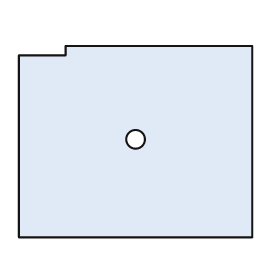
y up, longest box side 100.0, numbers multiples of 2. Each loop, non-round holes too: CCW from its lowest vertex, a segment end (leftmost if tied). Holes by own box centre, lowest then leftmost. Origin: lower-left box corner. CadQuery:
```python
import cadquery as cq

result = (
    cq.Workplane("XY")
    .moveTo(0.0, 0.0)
    .lineTo(100.0, 0.0)
    .lineTo(100.0, 82.0)
    .lineTo(20.0, 82.0)
    .lineTo(20.0, 78.0)
    .lineTo(0.0, 78.0)
    .close()
    .moveTo(50.0, 42.0)
    .circle(4.0)
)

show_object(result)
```